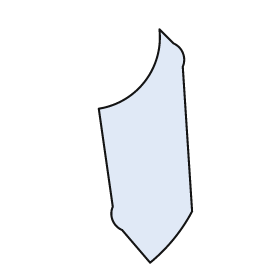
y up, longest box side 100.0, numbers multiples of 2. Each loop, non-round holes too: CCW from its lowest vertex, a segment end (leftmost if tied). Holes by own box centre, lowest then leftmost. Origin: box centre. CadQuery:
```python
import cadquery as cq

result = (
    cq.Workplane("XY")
    .moveTo(2.0, -50.0)
    .threePointArc((12.0, -40.0), (20.0, -28.0))
    .lineTo(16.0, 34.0)
    .threePointArc((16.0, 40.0), (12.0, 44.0))
    .lineTo(6.0, 50.0)
    .threePointArc((0.0, 28.0), (-20.0, 16.0))
    .lineTo(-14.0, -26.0)
    .threePointArc((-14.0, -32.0), (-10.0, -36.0))
    .close()
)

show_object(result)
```